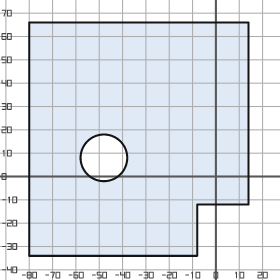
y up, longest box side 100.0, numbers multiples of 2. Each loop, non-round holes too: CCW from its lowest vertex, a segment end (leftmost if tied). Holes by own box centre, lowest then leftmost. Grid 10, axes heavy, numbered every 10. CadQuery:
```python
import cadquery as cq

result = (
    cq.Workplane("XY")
    .moveTo(-80.0, -34.0)
    .lineTo(-8.0, -34.0)
    .lineTo(-8.0, -12.0)
    .lineTo(14.0, -12.0)
    .lineTo(14.0, 66.0)
    .lineTo(-80.0, 66.0)
    .close()
    .moveTo(-48.0, 8.0)
    .circle(10.0)
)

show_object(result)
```